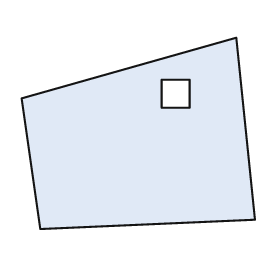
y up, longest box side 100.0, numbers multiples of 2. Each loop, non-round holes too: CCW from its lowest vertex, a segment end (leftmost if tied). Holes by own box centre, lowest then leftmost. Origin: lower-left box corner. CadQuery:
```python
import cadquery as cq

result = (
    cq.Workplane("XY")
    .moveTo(8.0, 0.0)
    .lineTo(100.0, 4.0)
    .lineTo(92.0, 82.0)
    .lineTo(0.0, 56.0)
    .close()
    .moveTo(60.0, 52.0)
    .lineTo(72.0, 52.0)
    .lineTo(72.0, 64.0)
    .lineTo(60.0, 64.0)
    .close()
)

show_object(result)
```